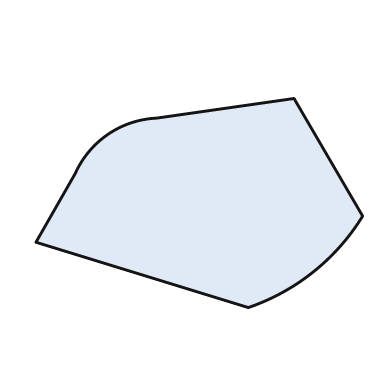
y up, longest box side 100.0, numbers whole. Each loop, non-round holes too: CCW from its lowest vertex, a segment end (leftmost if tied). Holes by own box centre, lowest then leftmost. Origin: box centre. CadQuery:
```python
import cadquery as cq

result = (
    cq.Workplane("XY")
    .moveTo(15.0, -32.0)
    .threePointArc((35.0, -21.0), (50.0, -4.0))
    .lineTo(29.0, 32.0)
    .lineTo(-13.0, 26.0)
    .threePointArc((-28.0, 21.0), (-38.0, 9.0))
    .lineTo(-50.0, -12.0)
    .close()
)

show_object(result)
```